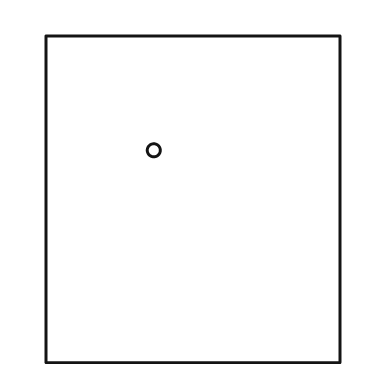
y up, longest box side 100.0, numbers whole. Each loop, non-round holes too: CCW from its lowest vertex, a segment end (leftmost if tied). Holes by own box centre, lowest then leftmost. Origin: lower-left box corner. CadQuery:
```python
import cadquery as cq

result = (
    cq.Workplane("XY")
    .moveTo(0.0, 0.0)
    .lineTo(90.0, 0.0)
    .lineTo(90.0, 100.0)
    .lineTo(0.0, 100.0)
    .close()
    .moveTo(33.0, 65.0)
    .circle(2.0)
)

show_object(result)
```